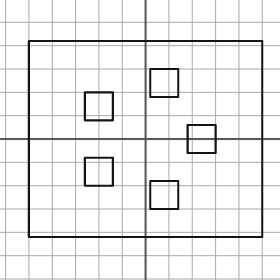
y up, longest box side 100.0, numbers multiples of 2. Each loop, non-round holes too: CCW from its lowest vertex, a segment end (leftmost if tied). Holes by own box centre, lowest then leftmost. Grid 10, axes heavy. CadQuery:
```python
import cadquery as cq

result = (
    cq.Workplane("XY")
    .moveTo(-50.0, -42.0)
    .lineTo(50.0, -42.0)
    .lineTo(50.0, 42.0)
    .lineTo(-50.0, 42.0)
    .close()
    .moveTo(2.0, -30.0)
    .lineTo(14.0, -30.0)
    .lineTo(14.0, -18.0)
    .lineTo(2.0, -18.0)
    .close()
    .moveTo(-26.0, -20.0)
    .lineTo(-14.0, -20.0)
    .lineTo(-14.0, -8.0)
    .lineTo(-26.0, -8.0)
    .close()
    .moveTo(18.0, -6.0)
    .lineTo(30.0, -6.0)
    .lineTo(30.0, 6.0)
    .lineTo(18.0, 6.0)
    .close()
    .moveTo(-26.0, 8.0)
    .lineTo(-14.0, 8.0)
    .lineTo(-14.0, 20.0)
    .lineTo(-26.0, 20.0)
    .close()
    .moveTo(2.0, 18.0)
    .lineTo(14.0, 18.0)
    .lineTo(14.0, 30.0)
    .lineTo(2.0, 30.0)
    .close()
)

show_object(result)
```